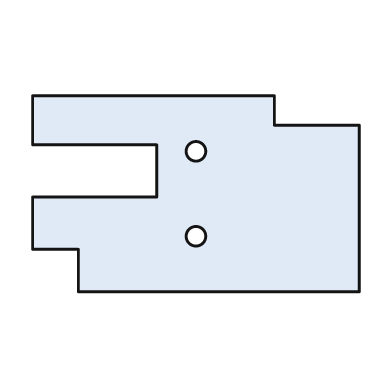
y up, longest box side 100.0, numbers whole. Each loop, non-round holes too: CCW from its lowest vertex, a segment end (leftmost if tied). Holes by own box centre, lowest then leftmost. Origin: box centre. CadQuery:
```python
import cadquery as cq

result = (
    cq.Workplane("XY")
    .moveTo(-36.0, -30.0)
    .lineTo(50.0, -30.0)
    .lineTo(50.0, 21.0)
    .lineTo(24.0, 21.0)
    .lineTo(24.0, 30.0)
    .lineTo(-50.0, 30.0)
    .lineTo(-50.0, 15.0)
    .lineTo(-12.0, 15.0)
    .lineTo(-12.0, -1.0)
    .lineTo(-50.0, -1.0)
    .lineTo(-50.0, -17.0)
    .lineTo(-36.0, -17.0)
    .close()
    .moveTo(0.0, -13.0)
    .circle(3.0)
    .moveTo(0.0, 13.0)
    .circle(3.0)
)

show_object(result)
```